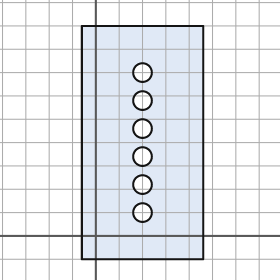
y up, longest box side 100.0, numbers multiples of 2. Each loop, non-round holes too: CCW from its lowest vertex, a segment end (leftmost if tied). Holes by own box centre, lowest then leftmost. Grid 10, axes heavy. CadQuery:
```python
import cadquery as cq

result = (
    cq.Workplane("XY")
    .moveTo(-6.0, -10.0)
    .lineTo(46.0, -10.0)
    .lineTo(46.0, 90.0)
    .lineTo(-6.0, 90.0)
    .close()
    .moveTo(20.0, 10.0)
    .circle(4.0)
    .moveTo(20.0, 22.0)
    .circle(4.0)
    .moveTo(20.0, 34.0)
    .circle(4.0)
    .moveTo(20.0, 46.0)
    .circle(4.0)
    .moveTo(20.0, 58.0)
    .circle(4.0)
    .moveTo(20.0, 70.0)
    .circle(4.0)
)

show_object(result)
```